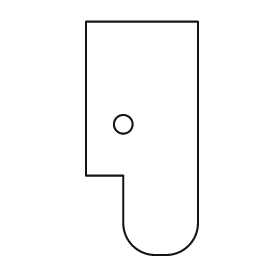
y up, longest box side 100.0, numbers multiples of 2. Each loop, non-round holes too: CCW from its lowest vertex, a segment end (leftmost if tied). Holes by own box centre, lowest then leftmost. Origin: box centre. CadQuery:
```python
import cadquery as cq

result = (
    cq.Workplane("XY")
    .moveTo(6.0, -50.0)
    .lineTo(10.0, -50.0)
    .threePointArc((20.0, -46.0), (24.0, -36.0))
    .lineTo(24.0, 50.0)
    .lineTo(-24.0, 50.0)
    .lineTo(-24.0, -16.0)
    .lineTo(-8.0, -16.0)
    .lineTo(-8.0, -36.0)
    .threePointArc((-4.0, -46.0), (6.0, -50.0))
    .close()
    .moveTo(-8.0, 6.0)
    .circle(4.0)
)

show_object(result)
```